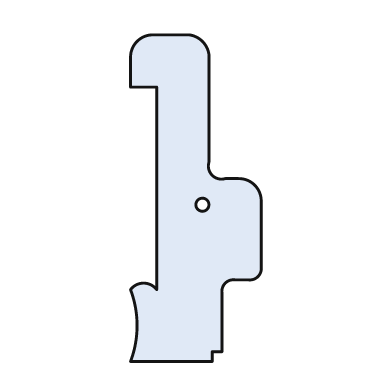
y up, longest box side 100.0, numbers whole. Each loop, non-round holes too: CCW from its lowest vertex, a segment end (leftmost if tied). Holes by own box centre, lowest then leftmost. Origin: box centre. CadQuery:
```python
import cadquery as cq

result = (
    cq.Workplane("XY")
    .moveTo(-20.0, -50.0)
    .lineTo(5.0, -50.0)
    .lineTo(5.0, -47.0)
    .lineTo(8.0, -47.0)
    .lineTo(8.0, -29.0)
    .threePointArc((9.0, -26.0), (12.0, -25.0))
    .lineTo(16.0, -25.0)
    .threePointArc((19.0, -24.0), (20.0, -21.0))
    .lineTo(20.0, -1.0)
    .threePointArc((18.0, 4.0), (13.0, 6.0))
    .lineTo(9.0, 6.0)
    .threePointArc((5.0, 7.0), (4.0, 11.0))
    .lineTo(4.0, 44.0)
    .threePointArc((2.0, 48.0), (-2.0, 50.0))
    .lineTo(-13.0, 50.0)
    .threePointArc((-18.0, 48.0), (-20.0, 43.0))
    .lineTo(-20.0, 34.0)
    .lineTo(-12.0, 34.0)
    .lineTo(-12.0, -28.0)
    .threePointArc((-16.0, -26.0), (-20.0, -28.0))
    .threePointArc((-18.0, -39.0), (-20.0, -50.0))
    .close()
    .moveTo(2.0, -2.0)
    .circle(2.0)
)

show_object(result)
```